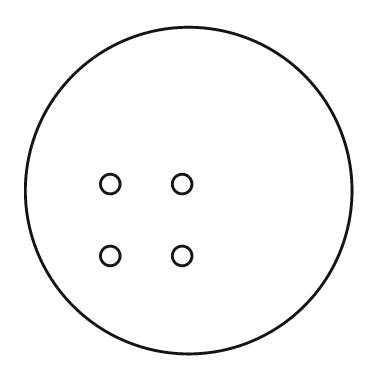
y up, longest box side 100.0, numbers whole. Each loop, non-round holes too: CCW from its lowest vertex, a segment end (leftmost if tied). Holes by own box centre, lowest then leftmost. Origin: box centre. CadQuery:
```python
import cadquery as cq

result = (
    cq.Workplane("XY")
    .moveTo(0.0, 0.0)
    .circle(50.0)
    .moveTo(-24.0, -20.0)
    .circle(3.0)
    .moveTo(-2.0, -20.0)
    .circle(3.0)
    .moveTo(-24.0, 2.0)
    .circle(3.0)
    .moveTo(-2.0, 2.0)
    .circle(3.0)
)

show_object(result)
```